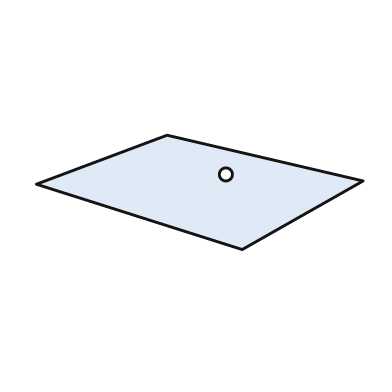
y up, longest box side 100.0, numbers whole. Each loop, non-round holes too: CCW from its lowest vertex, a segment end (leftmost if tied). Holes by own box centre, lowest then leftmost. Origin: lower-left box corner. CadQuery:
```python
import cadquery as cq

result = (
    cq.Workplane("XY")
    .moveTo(63.0, 0.0)
    .lineTo(100.0, 21.0)
    .lineTo(40.0, 35.0)
    .lineTo(0.0, 20.0)
    .close()
    .moveTo(58.0, 23.0)
    .circle(2.0)
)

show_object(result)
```